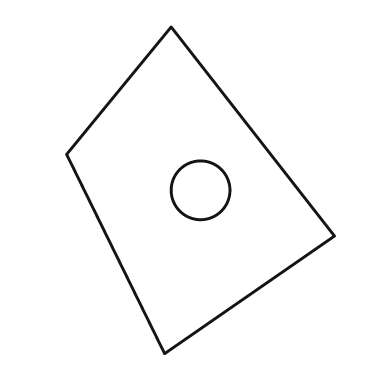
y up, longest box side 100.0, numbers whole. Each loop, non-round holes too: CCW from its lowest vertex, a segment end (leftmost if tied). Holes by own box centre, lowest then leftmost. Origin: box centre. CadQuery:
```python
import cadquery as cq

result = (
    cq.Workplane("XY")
    .moveTo(-11.0, -50.0)
    .lineTo(41.0, -14.0)
    .lineTo(-9.0, 50.0)
    .lineTo(-41.0, 11.0)
    .close()
    .moveTo(0.0, 0.0)
    .circle(9.0)
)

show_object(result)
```